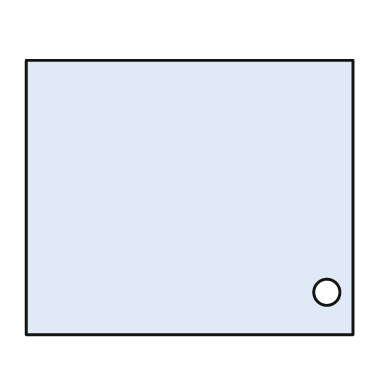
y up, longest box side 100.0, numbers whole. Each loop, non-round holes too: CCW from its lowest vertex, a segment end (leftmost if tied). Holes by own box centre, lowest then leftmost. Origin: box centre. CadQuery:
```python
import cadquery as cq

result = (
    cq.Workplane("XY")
    .moveTo(-50.0, -42.0)
    .lineTo(50.0, -42.0)
    .lineTo(50.0, 42.0)
    .lineTo(-50.0, 42.0)
    .close()
    .moveTo(42.0, -29.0)
    .circle(4.0)
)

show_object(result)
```